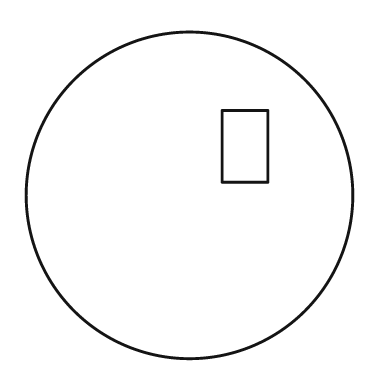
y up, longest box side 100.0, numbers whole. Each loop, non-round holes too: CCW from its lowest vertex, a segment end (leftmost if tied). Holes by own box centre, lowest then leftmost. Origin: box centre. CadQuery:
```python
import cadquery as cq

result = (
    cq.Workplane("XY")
    .moveTo(0.0, 0.0)
    .circle(50.0)
    .moveTo(10.0, 4.0)
    .lineTo(24.0, 4.0)
    .lineTo(24.0, 26.0)
    .lineTo(10.0, 26.0)
    .close()
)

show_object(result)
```